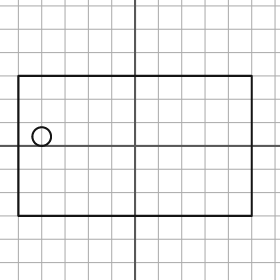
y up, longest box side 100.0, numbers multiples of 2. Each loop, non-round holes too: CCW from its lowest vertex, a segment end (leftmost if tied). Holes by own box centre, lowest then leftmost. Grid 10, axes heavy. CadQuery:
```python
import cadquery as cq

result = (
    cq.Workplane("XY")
    .moveTo(-50.0, -30.0)
    .lineTo(50.0, -30.0)
    .lineTo(50.0, 30.0)
    .lineTo(-50.0, 30.0)
    .close()
    .moveTo(-40.0, 4.0)
    .circle(4.0)
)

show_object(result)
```